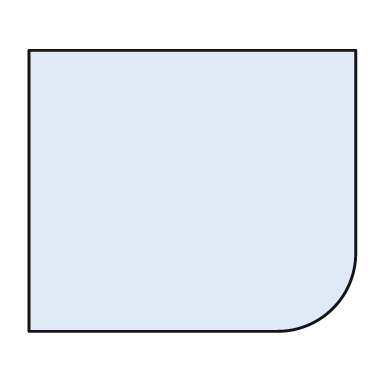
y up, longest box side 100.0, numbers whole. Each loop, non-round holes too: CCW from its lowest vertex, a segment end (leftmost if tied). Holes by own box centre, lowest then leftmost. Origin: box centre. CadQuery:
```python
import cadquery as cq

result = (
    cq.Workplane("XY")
    .moveTo(-50.0, -43.0)
    .lineTo(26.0, -43.0)
    .threePointArc((43.0, -36.0), (50.0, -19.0))
    .lineTo(50.0, 43.0)
    .lineTo(-50.0, 43.0)
    .close()
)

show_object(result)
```